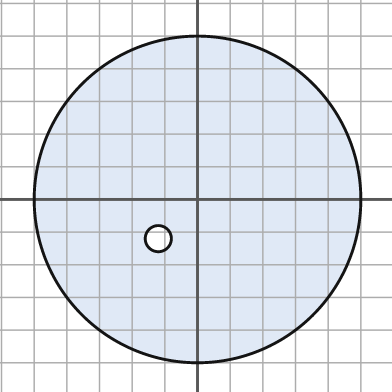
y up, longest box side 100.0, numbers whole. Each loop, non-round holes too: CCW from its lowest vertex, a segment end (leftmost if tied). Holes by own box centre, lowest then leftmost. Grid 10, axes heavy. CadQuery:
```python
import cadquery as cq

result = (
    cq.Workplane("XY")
    .moveTo(0.0, 0.0)
    .circle(50.0)
    .moveTo(-12.0, -12.0)
    .circle(4.0)
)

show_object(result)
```